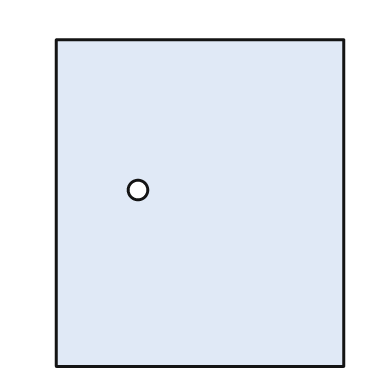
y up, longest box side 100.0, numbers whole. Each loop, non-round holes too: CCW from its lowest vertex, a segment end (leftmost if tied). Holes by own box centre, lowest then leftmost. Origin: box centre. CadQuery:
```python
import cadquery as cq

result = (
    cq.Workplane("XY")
    .moveTo(-44.0, -50.0)
    .lineTo(44.0, -50.0)
    .lineTo(44.0, 50.0)
    .lineTo(-44.0, 50.0)
    .close()
    .moveTo(-19.0, 4.0)
    .circle(3.0)
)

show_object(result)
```